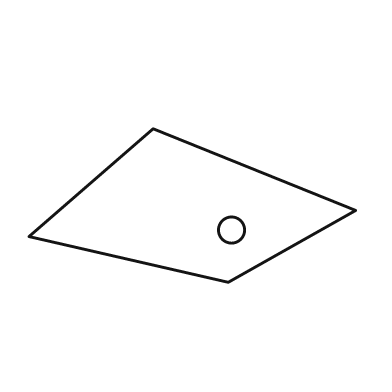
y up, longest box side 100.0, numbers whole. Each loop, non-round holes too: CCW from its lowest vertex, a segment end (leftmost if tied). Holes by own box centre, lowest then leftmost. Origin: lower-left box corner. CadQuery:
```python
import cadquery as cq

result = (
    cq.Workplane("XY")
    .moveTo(61.0, 0.0)
    .lineTo(100.0, 22.0)
    .lineTo(38.0, 47.0)
    .lineTo(0.0, 14.0)
    .close()
    .moveTo(62.0, 16.0)
    .circle(4.0)
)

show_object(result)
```